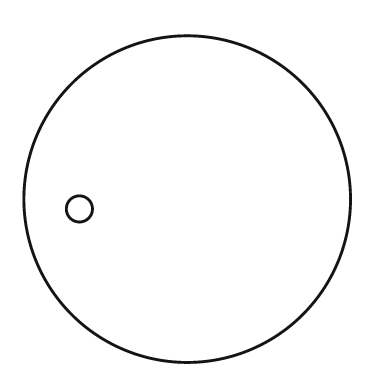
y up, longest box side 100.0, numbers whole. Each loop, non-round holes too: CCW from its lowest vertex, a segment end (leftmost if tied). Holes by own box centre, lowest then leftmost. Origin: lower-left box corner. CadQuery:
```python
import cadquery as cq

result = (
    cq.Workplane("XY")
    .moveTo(50.0, 50.0)
    .circle(50.0)
    .moveTo(17.0, 47.0)
    .circle(4.0)
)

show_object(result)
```